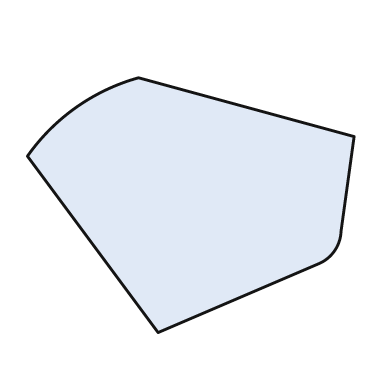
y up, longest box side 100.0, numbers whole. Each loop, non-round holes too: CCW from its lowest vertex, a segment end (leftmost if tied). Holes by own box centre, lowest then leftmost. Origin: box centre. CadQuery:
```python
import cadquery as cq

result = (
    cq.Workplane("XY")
    .moveTo(-10.0, -39.0)
    .lineTo(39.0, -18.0)
    .threePointArc((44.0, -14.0), (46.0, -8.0))
    .lineTo(50.0, 21.0)
    .lineTo(-16.0, 39.0)
    .threePointArc((-35.0, 30.0), (-50.0, 15.0))
    .close()
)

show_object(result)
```